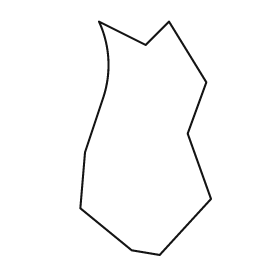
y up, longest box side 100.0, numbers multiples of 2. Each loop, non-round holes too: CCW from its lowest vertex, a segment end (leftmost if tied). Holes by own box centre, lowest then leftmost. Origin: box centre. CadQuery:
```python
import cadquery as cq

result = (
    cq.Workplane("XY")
    .moveTo(6.0, -50.0)
    .lineTo(28.0, -26.0)
    .lineTo(18.0, 2.0)
    .lineTo(26.0, 24.0)
    .lineTo(10.0, 50.0)
    .lineTo(0.0, 40.0)
    .lineTo(-20.0, 50.0)
    .threePointArc((-16.0, 34.0), (-18.0, 18.0))
    .lineTo(-26.0, -6.0)
    .lineTo(-28.0, -30.0)
    .lineTo(-6.0, -48.0)
    .close()
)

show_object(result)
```